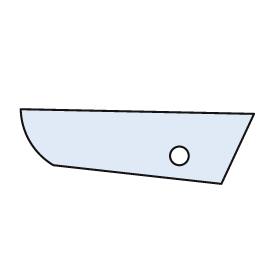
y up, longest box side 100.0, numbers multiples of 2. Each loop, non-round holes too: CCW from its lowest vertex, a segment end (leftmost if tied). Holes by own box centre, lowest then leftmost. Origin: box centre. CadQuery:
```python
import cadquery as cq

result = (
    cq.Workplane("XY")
    .moveTo(36.0, -16.0)
    .lineTo(50.0, 14.0)
    .lineTo(-50.0, 16.0)
    .threePointArc((-46.0, 2.0), (-36.0, -8.0))
    .close()
    .moveTo(18.0, -4.0)
    .circle(4.0)
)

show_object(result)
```